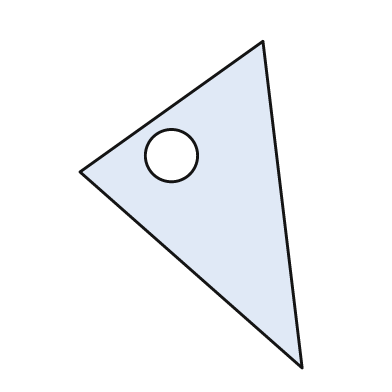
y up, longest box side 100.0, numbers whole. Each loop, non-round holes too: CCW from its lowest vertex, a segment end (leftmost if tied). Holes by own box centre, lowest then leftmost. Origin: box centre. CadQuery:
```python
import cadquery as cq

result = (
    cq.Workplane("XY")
    .moveTo(34.0, -50.0)
    .lineTo(22.0, 50.0)
    .lineTo(-34.0, 10.0)
    .close()
    .moveTo(-6.0, 15.0)
    .circle(8.0)
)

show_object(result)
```